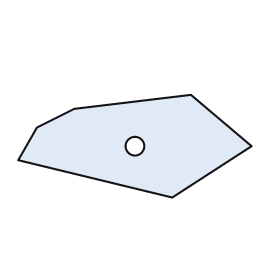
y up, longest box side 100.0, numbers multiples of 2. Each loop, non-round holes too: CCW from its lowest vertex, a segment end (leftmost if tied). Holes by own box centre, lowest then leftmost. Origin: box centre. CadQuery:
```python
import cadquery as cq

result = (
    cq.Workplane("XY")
    .moveTo(16.0, -22.0)
    .lineTo(50.0, 0.0)
    .lineTo(24.0, 22.0)
    .lineTo(-26.0, 16.0)
    .lineTo(-42.0, 8.0)
    .lineTo(-50.0, -6.0)
    .close()
    .moveTo(0.0, 0.0)
    .circle(4.0)
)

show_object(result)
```